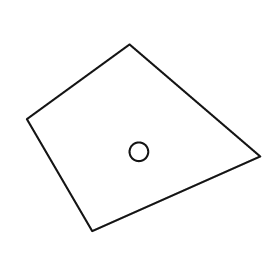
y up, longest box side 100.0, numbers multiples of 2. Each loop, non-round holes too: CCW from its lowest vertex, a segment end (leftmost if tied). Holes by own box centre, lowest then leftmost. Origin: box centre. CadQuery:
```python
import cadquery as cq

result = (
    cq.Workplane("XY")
    .moveTo(-22.0, -40.0)
    .lineTo(50.0, -8.0)
    .lineTo(-6.0, 40.0)
    .lineTo(-50.0, 8.0)
    .close()
    .moveTo(-2.0, -6.0)
    .circle(4.0)
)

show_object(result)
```